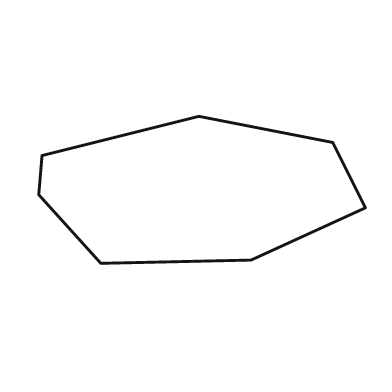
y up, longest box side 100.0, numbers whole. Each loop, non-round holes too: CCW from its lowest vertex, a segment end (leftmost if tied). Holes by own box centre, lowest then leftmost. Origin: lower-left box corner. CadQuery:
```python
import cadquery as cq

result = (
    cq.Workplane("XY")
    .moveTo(19.0, 0.0)
    .lineTo(65.0, 1.0)
    .lineTo(100.0, 17.0)
    .lineTo(90.0, 37.0)
    .lineTo(49.0, 45.0)
    .lineTo(1.0, 33.0)
    .lineTo(0.0, 21.0)
    .close()
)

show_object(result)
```